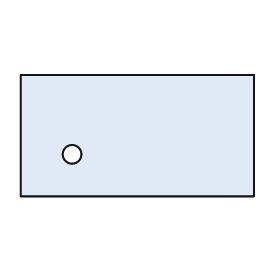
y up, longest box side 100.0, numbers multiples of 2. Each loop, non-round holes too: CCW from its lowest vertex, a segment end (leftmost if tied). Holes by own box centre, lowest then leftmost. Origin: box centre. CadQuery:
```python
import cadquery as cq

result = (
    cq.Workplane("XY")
    .moveTo(-50.0, -26.0)
    .lineTo(50.0, -26.0)
    .lineTo(50.0, 26.0)
    .lineTo(-50.0, 26.0)
    .close()
    .moveTo(-28.0, -8.0)
    .circle(4.0)
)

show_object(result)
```